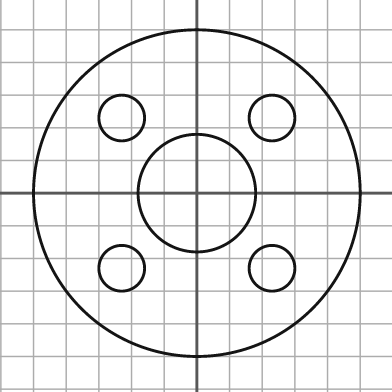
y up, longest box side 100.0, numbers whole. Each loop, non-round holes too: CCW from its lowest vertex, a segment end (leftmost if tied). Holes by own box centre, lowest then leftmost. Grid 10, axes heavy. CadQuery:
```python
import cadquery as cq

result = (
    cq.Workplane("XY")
    .moveTo(0.0, 0.0)
    .circle(50.0)
    .moveTo(-23.0, -23.0)
    .circle(7.0)
    .moveTo(23.0, -23.0)
    .circle(7.0)
    .moveTo(0.0, 0.0)
    .circle(18.0)
    .moveTo(-23.0, 23.0)
    .circle(7.0)
    .moveTo(23.0, 23.0)
    .circle(7.0)
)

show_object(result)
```